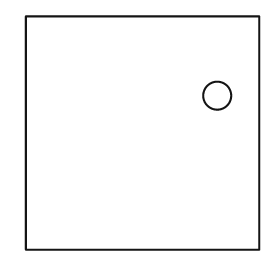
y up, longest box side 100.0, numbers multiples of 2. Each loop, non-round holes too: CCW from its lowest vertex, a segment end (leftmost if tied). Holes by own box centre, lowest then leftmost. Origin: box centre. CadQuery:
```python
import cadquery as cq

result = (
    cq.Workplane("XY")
    .moveTo(-50.0, -50.0)
    .lineTo(50.0, -50.0)
    .lineTo(50.0, 50.0)
    .lineTo(-50.0, 50.0)
    .close()
    .moveTo(32.0, 16.0)
    .circle(6.0)
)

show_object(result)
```